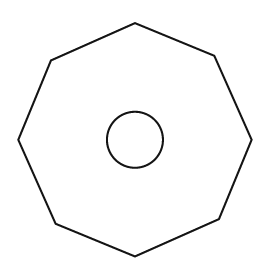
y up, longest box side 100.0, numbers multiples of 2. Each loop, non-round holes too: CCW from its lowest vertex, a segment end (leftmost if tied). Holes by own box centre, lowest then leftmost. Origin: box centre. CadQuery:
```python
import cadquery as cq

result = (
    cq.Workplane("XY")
    .moveTo(0.0, -50.0)
    .lineTo(36.0, -34.0)
    .lineTo(50.0, 0.0)
    .lineTo(34.0, 36.0)
    .lineTo(0.0, 50.0)
    .lineTo(-36.0, 34.0)
    .lineTo(-50.0, 0.0)
    .lineTo(-34.0, -36.0)
    .close()
    .moveTo(0.0, 0.0)
    .circle(12.0)
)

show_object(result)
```